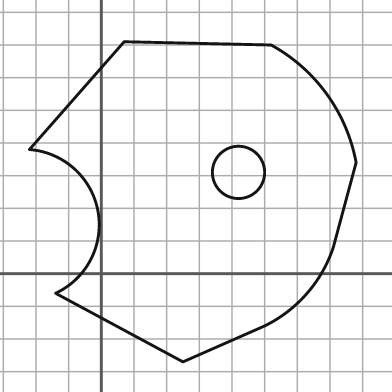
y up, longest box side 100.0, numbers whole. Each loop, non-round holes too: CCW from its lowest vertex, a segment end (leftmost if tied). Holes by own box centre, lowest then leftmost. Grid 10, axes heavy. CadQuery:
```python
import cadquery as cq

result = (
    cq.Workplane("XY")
    .moveTo(25.0, -27.0)
    .lineTo(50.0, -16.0)
    .threePointArc((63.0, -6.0), (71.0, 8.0))
    .lineTo(78.0, 34.0)
    .threePointArc((69.0, 55.0), (52.0, 70.0))
    .lineTo(7.0, 71.0)
    .lineTo(-22.0, 38.0)
    .threePointArc((-1.0, 19.0), (-14.0, -6.0))
    .close()
    .moveTo(42.0, 31.0)
    .circle(8.0)
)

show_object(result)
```